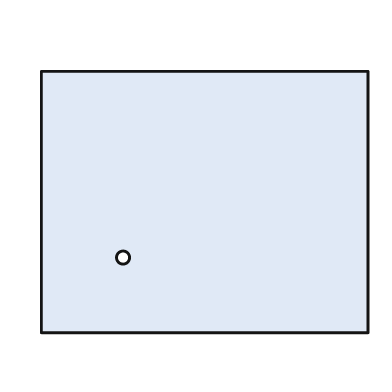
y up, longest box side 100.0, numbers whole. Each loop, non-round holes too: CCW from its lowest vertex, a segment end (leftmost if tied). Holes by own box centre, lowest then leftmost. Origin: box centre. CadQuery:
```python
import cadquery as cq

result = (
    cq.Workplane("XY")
    .moveTo(-50.0, -40.0)
    .lineTo(50.0, -40.0)
    .lineTo(50.0, 40.0)
    .lineTo(-50.0, 40.0)
    .close()
    .moveTo(-25.0, -17.0)
    .circle(2.0)
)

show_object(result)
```